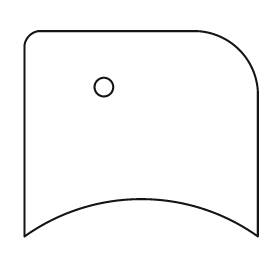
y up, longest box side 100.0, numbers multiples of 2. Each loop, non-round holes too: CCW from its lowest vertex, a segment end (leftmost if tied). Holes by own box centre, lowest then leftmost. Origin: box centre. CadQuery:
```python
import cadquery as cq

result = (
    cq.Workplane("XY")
    .moveTo(-50.0, -44.0)
    .threePointArc((0.0, -28.0), (50.0, -44.0))
    .lineTo(50.0, 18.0)
    .threePointArc((42.0, 36.0), (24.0, 44.0))
    .lineTo(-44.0, 44.0)
    .threePointArc((-48.0, 42.0), (-50.0, 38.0))
    .close()
    .moveTo(-16.0, 20.0)
    .circle(4.0)
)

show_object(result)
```